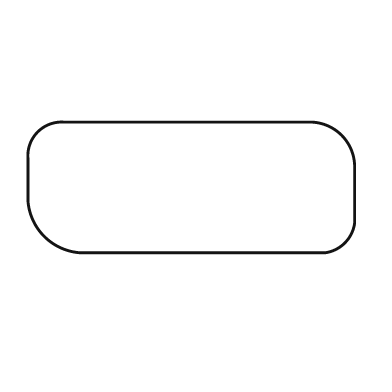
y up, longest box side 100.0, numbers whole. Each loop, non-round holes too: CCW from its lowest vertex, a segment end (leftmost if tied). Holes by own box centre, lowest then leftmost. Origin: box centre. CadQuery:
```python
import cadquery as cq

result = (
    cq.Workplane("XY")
    .moveTo(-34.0, -20.0)
    .lineTo(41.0, -20.0)
    .threePointArc((47.0, -17.0), (50.0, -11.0))
    .lineTo(50.0, 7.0)
    .threePointArc((46.0, 16.0), (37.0, 20.0))
    .lineTo(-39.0, 20.0)
    .threePointArc((-47.0, 17.0), (-50.0, 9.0))
    .lineTo(-50.0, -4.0)
    .threePointArc((-45.0, -15.0), (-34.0, -20.0))
    .close()
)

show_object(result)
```